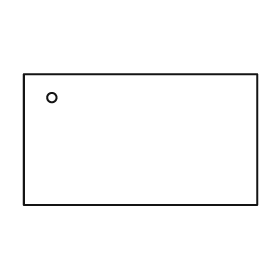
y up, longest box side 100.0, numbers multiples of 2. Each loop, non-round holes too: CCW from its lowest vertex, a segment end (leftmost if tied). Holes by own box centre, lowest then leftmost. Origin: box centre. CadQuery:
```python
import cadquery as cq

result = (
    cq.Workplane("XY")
    .moveTo(-50.0, -28.0)
    .lineTo(50.0, -28.0)
    .lineTo(50.0, 28.0)
    .lineTo(-50.0, 28.0)
    .close()
    .moveTo(-38.0, 18.0)
    .circle(2.0)
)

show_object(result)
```